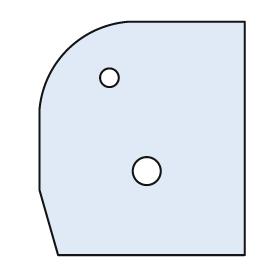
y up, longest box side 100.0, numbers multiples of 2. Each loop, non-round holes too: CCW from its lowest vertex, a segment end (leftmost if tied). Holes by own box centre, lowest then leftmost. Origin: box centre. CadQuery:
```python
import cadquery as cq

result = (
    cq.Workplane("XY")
    .moveTo(-36.0, -50.0)
    .lineTo(44.0, -50.0)
    .lineTo(44.0, 50.0)
    .lineTo(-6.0, 50.0)
    .threePointArc((-32.0, 38.0), (-44.0, 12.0))
    .lineTo(-44.0, -22.0)
    .close()
    .moveTo(2.0, -14.0)
    .circle(6.0)
    .moveTo(-14.0, 26.0)
    .circle(4.0)
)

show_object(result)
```